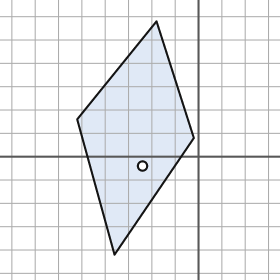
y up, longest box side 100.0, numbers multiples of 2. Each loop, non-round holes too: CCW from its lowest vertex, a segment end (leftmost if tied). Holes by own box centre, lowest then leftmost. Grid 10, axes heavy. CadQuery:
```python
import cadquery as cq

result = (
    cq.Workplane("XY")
    .moveTo(-36.0, -42.0)
    .lineTo(-2.0, 8.0)
    .lineTo(-18.0, 58.0)
    .lineTo(-52.0, 16.0)
    .close()
    .moveTo(-24.0, -4.0)
    .circle(2.0)
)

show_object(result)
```